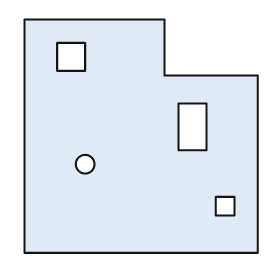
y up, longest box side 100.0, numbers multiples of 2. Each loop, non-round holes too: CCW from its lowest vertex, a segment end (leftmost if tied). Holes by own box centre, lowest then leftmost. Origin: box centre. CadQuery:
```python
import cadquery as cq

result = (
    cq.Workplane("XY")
    .moveTo(-50.0, -50.0)
    .lineTo(50.0, -50.0)
    .lineTo(50.0, 26.0)
    .lineTo(10.0, 26.0)
    .lineTo(10.0, 50.0)
    .lineTo(-50.0, 50.0)
    .close()
    .moveTo(32.0, -34.0)
    .lineTo(40.0, -34.0)
    .lineTo(40.0, -26.0)
    .lineTo(32.0, -26.0)
    .close()
    .moveTo(-24.0, -12.0)
    .circle(4.0)
    .moveTo(16.0, -6.0)
    .lineTo(28.0, -6.0)
    .lineTo(28.0, 14.0)
    .lineTo(16.0, 14.0)
    .close()
    .moveTo(-36.0, 28.0)
    .lineTo(-24.0, 28.0)
    .lineTo(-24.0, 40.0)
    .lineTo(-36.0, 40.0)
    .close()
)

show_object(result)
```